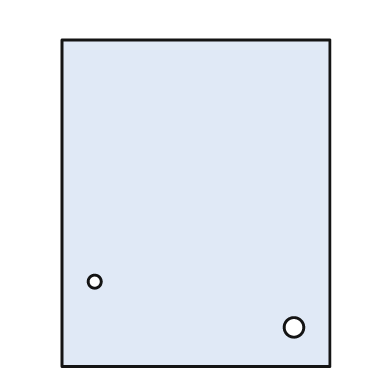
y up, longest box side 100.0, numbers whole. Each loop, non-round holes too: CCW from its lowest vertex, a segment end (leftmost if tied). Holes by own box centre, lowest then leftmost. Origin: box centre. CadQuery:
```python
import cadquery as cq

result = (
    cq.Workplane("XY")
    .moveTo(-41.0, -50.0)
    .lineTo(41.0, -50.0)
    .lineTo(41.0, 50.0)
    .lineTo(-41.0, 50.0)
    .close()
    .moveTo(30.0, -38.0)
    .circle(3.0)
    .moveTo(-31.0, -24.0)
    .circle(2.0)
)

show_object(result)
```